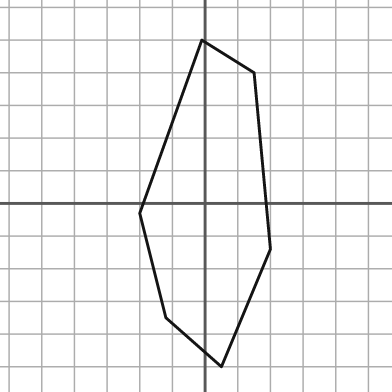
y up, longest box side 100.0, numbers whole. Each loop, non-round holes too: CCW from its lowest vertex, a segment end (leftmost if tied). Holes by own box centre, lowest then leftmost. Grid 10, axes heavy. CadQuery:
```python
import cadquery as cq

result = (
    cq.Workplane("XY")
    .moveTo(5.0, -50.0)
    .lineTo(20.0, -14.0)
    .lineTo(15.0, 40.0)
    .lineTo(-1.0, 50.0)
    .lineTo(-20.0, -3.0)
    .lineTo(-12.0, -35.0)
    .close()
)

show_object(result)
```